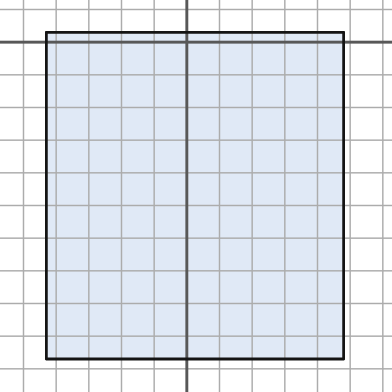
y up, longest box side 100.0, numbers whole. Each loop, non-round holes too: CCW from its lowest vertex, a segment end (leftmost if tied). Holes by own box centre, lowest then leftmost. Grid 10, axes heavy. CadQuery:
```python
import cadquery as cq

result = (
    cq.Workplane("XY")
    .moveTo(-43.0, -97.0)
    .lineTo(48.0, -97.0)
    .lineTo(48.0, 3.0)
    .lineTo(-43.0, 3.0)
    .close()
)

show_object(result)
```